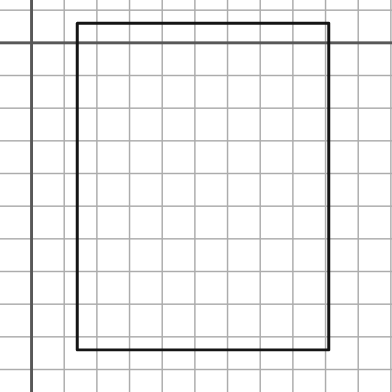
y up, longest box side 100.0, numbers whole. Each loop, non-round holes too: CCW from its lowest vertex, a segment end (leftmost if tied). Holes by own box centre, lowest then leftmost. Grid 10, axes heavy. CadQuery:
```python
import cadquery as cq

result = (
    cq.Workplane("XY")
    .moveTo(14.0, -94.0)
    .lineTo(91.0, -94.0)
    .lineTo(91.0, 6.0)
    .lineTo(14.0, 6.0)
    .close()
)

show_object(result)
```